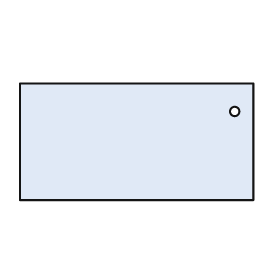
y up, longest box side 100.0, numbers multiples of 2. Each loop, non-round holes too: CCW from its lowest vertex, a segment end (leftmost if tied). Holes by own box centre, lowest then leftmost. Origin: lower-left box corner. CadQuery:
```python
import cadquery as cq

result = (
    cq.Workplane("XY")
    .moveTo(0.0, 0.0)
    .lineTo(100.0, 0.0)
    .lineTo(100.0, 50.0)
    .lineTo(0.0, 50.0)
    .close()
    .moveTo(92.0, 38.0)
    .circle(2.0)
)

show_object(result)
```